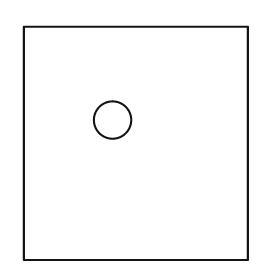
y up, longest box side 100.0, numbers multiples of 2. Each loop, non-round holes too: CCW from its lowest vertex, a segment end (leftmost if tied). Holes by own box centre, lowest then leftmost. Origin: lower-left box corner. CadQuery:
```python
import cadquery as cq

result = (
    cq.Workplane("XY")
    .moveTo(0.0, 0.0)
    .lineTo(96.0, 0.0)
    .lineTo(96.0, 100.0)
    .lineTo(0.0, 100.0)
    .close()
    .moveTo(38.0, 60.0)
    .circle(8.0)
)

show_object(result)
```